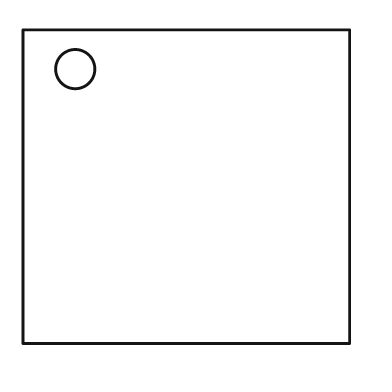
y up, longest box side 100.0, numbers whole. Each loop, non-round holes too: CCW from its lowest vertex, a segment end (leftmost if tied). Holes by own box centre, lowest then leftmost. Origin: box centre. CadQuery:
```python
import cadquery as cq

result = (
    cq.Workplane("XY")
    .moveTo(-50.0, -48.0)
    .lineTo(50.0, -48.0)
    .lineTo(50.0, 48.0)
    .lineTo(-50.0, 48.0)
    .close()
    .moveTo(-34.0, 36.0)
    .circle(6.0)
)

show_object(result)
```